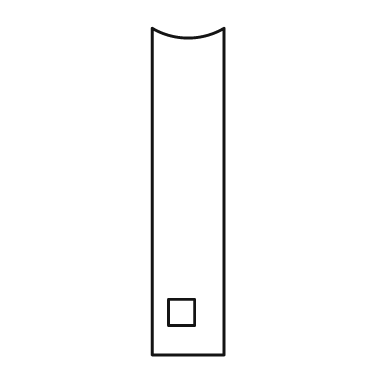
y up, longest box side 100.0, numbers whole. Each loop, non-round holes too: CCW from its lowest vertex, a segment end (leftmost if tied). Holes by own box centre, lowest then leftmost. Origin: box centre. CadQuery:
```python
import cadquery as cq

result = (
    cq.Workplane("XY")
    .moveTo(-11.0, -50.0)
    .lineTo(11.0, -50.0)
    .lineTo(11.0, 50.0)
    .threePointArc((0.0, 47.0), (-11.0, 50.0))
    .close()
    .moveTo(-6.0, -41.0)
    .lineTo(2.0, -41.0)
    .lineTo(2.0, -33.0)
    .lineTo(-6.0, -33.0)
    .close()
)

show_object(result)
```